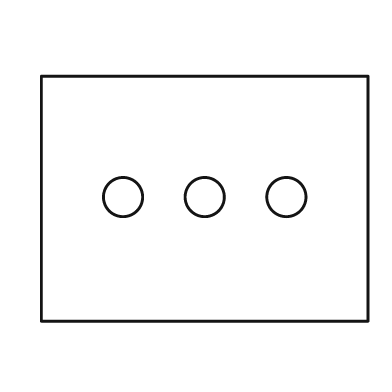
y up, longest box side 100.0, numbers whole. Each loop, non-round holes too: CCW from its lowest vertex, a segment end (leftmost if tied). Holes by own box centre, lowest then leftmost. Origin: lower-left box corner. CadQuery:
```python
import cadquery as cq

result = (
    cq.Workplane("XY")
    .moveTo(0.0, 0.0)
    .lineTo(100.0, 0.0)
    .lineTo(100.0, 75.0)
    .lineTo(0.0, 75.0)
    .close()
    .moveTo(25.0, 38.0)
    .circle(6.0)
    .moveTo(50.0, 38.0)
    .circle(6.0)
    .moveTo(75.0, 38.0)
    .circle(6.0)
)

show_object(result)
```